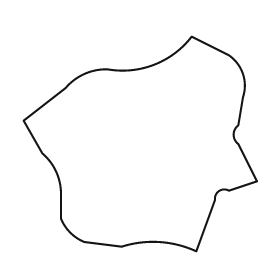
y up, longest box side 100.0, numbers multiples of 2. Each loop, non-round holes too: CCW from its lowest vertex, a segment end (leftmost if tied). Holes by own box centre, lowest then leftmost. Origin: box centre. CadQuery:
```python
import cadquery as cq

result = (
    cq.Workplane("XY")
    .moveTo(24.0, -46.0)
    .lineTo(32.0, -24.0)
    .threePointArc((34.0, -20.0), (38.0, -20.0))
    .lineTo(50.0, -16.0)
    .lineTo(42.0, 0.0)
    .threePointArc((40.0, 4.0), (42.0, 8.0))
    .lineTo(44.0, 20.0)
    .threePointArc((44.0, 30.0), (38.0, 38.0))
    .lineTo(22.0, 46.0)
    .threePointArc((6.0, 34.0), (-14.0, 32.0))
    .threePointArc((-24.0, 30.0), (-32.0, 24.0))
    .lineTo(-50.0, 10.0)
    .lineTo(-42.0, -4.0)
    .threePointArc((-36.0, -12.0), (-34.0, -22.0))
    .lineTo(-34.0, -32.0)
    .threePointArc((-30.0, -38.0), (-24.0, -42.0))
    .lineTo(-8.0, -44.0)
    .threePointArc((8.0, -42.0), (24.0, -46.0))
    .close()
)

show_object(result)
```